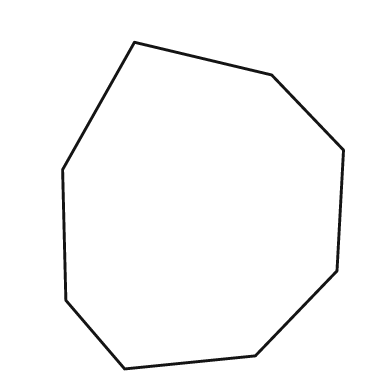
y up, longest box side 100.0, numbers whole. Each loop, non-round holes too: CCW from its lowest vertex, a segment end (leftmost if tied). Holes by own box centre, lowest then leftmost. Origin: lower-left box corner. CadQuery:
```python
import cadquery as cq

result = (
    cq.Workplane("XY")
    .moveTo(19.0, 0.0)
    .lineTo(59.0, 4.0)
    .lineTo(84.0, 30.0)
    .lineTo(86.0, 67.0)
    .lineTo(64.0, 90.0)
    .lineTo(22.0, 100.0)
    .lineTo(0.0, 61.0)
    .lineTo(1.0, 21.0)
    .close()
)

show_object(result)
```